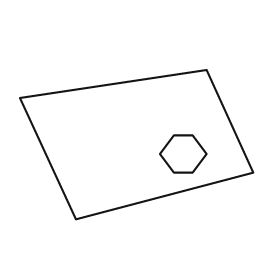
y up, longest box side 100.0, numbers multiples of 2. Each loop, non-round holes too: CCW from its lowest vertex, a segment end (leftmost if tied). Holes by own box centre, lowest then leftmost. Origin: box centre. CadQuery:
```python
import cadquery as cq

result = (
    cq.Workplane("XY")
    .moveTo(-26.0, -32.0)
    .lineTo(50.0, -12.0)
    .lineTo(30.0, 32.0)
    .lineTo(-50.0, 20.0)
    .close()
    .moveTo(16.0, -12.0)
    .lineTo(24.0, -12.0)
    .lineTo(30.0, -4.0)
    .lineTo(24.0, 4.0)
    .lineTo(16.0, 4.0)
    .lineTo(10.0, -4.0)
    .close()
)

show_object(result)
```